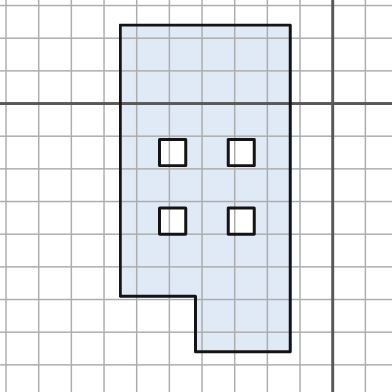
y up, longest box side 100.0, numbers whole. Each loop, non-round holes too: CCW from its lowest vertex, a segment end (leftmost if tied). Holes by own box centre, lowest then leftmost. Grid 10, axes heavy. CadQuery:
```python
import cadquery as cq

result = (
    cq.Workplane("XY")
    .moveTo(-42.0, -76.0)
    .lineTo(-13.0, -76.0)
    .lineTo(-13.0, 24.0)
    .lineTo(-65.0, 24.0)
    .lineTo(-65.0, -59.0)
    .lineTo(-42.0, -59.0)
    .close()
    .moveTo(-53.0, -40.0)
    .lineTo(-45.0, -40.0)
    .lineTo(-45.0, -32.0)
    .lineTo(-53.0, -32.0)
    .close()
    .moveTo(-32.0, -40.0)
    .lineTo(-24.0, -40.0)
    .lineTo(-24.0, -32.0)
    .lineTo(-32.0, -32.0)
    .close()
    .moveTo(-53.0, -19.0)
    .lineTo(-45.0, -19.0)
    .lineTo(-45.0, -11.0)
    .lineTo(-53.0, -11.0)
    .close()
    .moveTo(-32.0, -19.0)
    .lineTo(-24.0, -19.0)
    .lineTo(-24.0, -11.0)
    .lineTo(-32.0, -11.0)
    .close()
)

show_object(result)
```